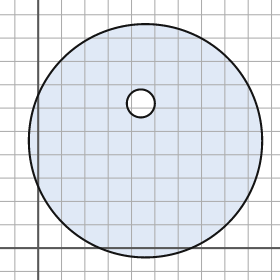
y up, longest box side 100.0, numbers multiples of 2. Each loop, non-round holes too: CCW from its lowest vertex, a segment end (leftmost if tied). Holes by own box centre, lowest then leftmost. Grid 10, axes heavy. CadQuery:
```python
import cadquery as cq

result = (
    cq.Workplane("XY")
    .moveTo(46.0, 46.0)
    .circle(50.0)
    .moveTo(44.0, 62.0)
    .circle(6.0)
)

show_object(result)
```